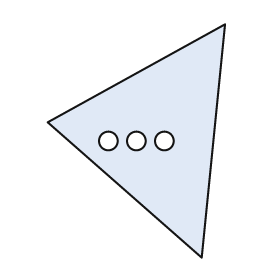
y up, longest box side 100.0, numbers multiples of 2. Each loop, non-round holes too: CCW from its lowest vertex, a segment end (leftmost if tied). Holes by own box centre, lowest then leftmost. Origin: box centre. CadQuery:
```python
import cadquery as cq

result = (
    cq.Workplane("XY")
    .moveTo(28.0, -50.0)
    .lineTo(38.0, 50.0)
    .lineTo(-38.0, 8.0)
    .close()
    .moveTo(-12.0, 0.0)
    .circle(4.0)
    .moveTo(0.0, 0.0)
    .circle(4.0)
    .moveTo(12.0, 0.0)
    .circle(4.0)
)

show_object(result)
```